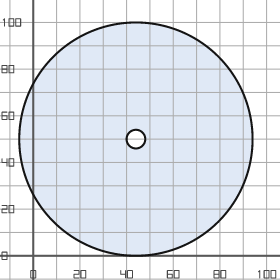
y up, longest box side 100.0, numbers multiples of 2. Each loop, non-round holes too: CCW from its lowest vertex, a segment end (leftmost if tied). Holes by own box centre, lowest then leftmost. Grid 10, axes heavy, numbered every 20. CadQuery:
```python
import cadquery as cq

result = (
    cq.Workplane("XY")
    .moveTo(44.0, 50.0)
    .circle(50.0)
    .moveTo(44.0, 50.0)
    .circle(4.0)
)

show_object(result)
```